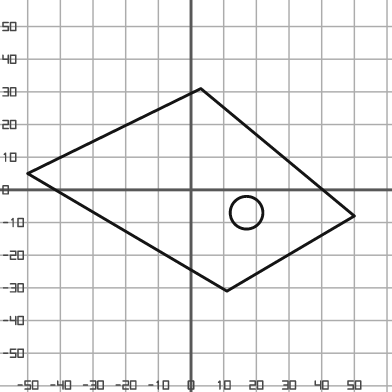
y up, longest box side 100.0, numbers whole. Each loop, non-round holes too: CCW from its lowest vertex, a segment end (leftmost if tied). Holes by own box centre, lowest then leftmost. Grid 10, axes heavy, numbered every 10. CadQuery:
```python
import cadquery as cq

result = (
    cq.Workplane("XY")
    .moveTo(11.0, -31.0)
    .lineTo(50.0, -8.0)
    .lineTo(3.0, 31.0)
    .lineTo(-50.0, 5.0)
    .close()
    .moveTo(17.0, -7.0)
    .circle(5.0)
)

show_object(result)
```